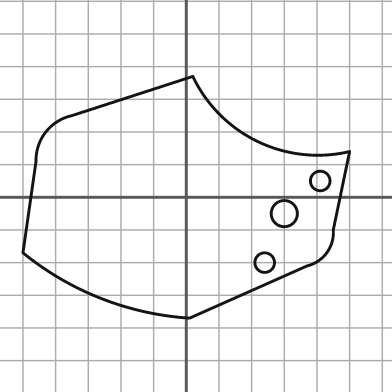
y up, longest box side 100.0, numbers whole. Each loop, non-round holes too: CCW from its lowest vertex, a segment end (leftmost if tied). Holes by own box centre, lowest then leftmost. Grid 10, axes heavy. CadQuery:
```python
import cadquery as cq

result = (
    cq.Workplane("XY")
    .moveTo(1.0, -37.0)
    .lineTo(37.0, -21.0)
    .threePointArc((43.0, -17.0), (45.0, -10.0))
    .lineTo(50.0, 14.0)
    .threePointArc((22.0, 17.0), (2.0, 37.0))
    .lineTo(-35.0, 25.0)
    .threePointArc((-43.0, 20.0), (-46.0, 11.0))
    .lineTo(-50.0, -17.0)
    .threePointArc((-26.0, -31.0), (1.0, -37.0))
    .close()
    .moveTo(24.0, -20.0)
    .circle(3.0)
    .moveTo(30.0, -5.0)
    .circle(4.0)
    .moveTo(41.0, 5.0)
    .circle(3.0)
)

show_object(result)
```